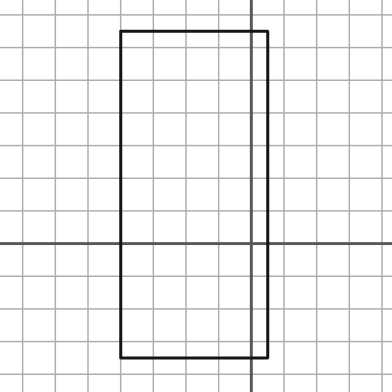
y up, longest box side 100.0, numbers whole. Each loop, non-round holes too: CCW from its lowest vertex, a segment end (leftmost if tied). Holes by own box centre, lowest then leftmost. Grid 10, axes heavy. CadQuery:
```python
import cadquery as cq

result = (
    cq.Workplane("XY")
    .moveTo(-40.0, -35.0)
    .lineTo(5.0, -35.0)
    .lineTo(5.0, 65.0)
    .lineTo(-40.0, 65.0)
    .close()
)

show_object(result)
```